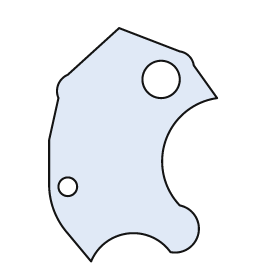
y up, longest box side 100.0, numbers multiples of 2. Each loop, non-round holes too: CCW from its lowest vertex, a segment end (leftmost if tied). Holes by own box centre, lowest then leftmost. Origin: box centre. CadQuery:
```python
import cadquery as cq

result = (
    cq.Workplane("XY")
    .moveTo(-18.0, -50.0)
    .threePointArc((-2.0, -38.0), (16.0, -46.0))
    .threePointArc((28.0, -38.0), (20.0, -26.0))
    .threePointArc((14.0, 2.0), (36.0, 20.0))
    .lineTo(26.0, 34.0)
    .threePointArc((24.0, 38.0), (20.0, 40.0))
    .lineTo(-6.0, 50.0)
    .lineTo(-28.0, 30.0)
    .threePointArc((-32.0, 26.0), (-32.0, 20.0))
    .lineTo(-36.0, 2.0)
    .lineTo(-36.0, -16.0)
    .threePointArc((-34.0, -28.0), (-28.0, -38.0))
    .close()
    .moveTo(-28.0, -18.0)
    .circle(4.0)
    .moveTo(12.0, 28.0)
    .circle(8.0)
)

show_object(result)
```